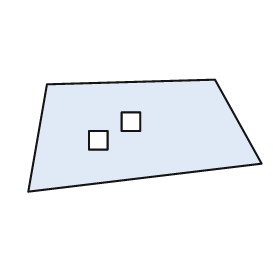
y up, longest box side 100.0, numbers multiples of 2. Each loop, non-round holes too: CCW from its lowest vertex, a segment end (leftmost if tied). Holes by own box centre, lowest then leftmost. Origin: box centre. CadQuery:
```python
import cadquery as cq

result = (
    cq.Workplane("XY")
    .moveTo(-50.0, -24.0)
    .lineTo(50.0, -12.0)
    .lineTo(30.0, 24.0)
    .lineTo(-42.0, 22.0)
    .close()
    .moveTo(-24.0, -6.0)
    .lineTo(-16.0, -6.0)
    .lineTo(-16.0, 2.0)
    .lineTo(-24.0, 2.0)
    .close()
    .moveTo(-10.0, 2.0)
    .lineTo(-2.0, 2.0)
    .lineTo(-2.0, 10.0)
    .lineTo(-10.0, 10.0)
    .close()
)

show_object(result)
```